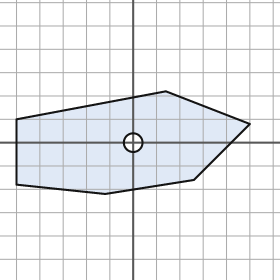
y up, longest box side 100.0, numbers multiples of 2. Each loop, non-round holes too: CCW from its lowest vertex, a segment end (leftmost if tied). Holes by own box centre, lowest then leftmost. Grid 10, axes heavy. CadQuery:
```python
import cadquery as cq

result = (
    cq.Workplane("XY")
    .moveTo(-12.0, -22.0)
    .lineTo(26.0, -16.0)
    .lineTo(50.0, 8.0)
    .lineTo(14.0, 22.0)
    .lineTo(-50.0, 10.0)
    .lineTo(-50.0, -18.0)
    .close()
    .moveTo(0.0, 0.0)
    .circle(4.0)
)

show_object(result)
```